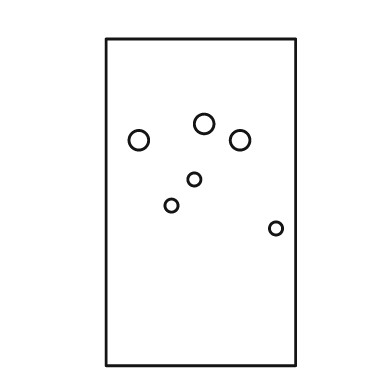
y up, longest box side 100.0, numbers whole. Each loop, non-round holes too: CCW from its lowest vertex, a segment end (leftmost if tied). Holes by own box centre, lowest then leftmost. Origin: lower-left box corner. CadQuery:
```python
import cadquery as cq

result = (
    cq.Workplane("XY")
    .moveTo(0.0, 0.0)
    .lineTo(58.0, 0.0)
    .lineTo(58.0, 100.0)
    .lineTo(0.0, 100.0)
    .close()
    .moveTo(52.0, 42.0)
    .circle(2.0)
    .moveTo(20.0, 49.0)
    .circle(2.0)
    .moveTo(27.0, 57.0)
    .circle(2.0)
    .moveTo(10.0, 69.0)
    .circle(3.0)
    .moveTo(41.0, 69.0)
    .circle(3.0)
    .moveTo(30.0, 74.0)
    .circle(3.0)
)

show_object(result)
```